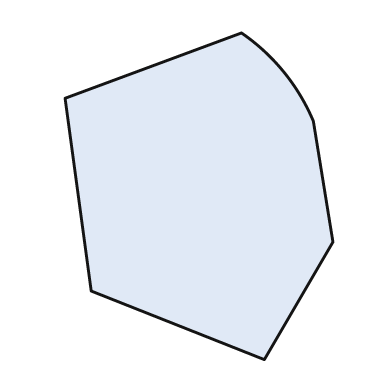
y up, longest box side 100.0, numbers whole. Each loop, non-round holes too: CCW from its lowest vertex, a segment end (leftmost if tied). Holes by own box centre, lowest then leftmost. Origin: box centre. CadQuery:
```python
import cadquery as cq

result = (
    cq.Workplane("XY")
    .moveTo(20.0, -50.0)
    .lineTo(41.0, -14.0)
    .lineTo(35.0, 23.0)
    .threePointArc((26.0, 38.0), (13.0, 50.0))
    .lineTo(-41.0, 30.0)
    .lineTo(-33.0, -29.0)
    .close()
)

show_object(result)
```